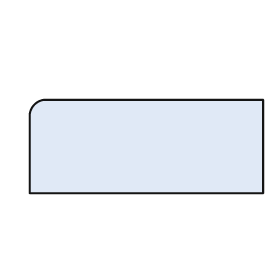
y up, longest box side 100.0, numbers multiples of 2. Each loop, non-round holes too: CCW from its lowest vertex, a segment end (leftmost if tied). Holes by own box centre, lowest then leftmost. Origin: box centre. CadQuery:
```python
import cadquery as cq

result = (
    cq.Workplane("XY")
    .moveTo(-50.0, -20.0)
    .lineTo(50.0, -20.0)
    .lineTo(50.0, 20.0)
    .lineTo(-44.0, 20.0)
    .threePointArc((-48.0, 18.0), (-50.0, 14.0))
    .close()
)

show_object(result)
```